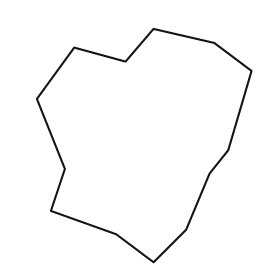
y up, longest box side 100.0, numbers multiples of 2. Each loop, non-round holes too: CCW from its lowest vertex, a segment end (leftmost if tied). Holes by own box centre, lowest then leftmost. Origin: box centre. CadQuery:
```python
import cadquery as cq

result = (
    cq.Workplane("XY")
    .moveTo(4.0, -50.0)
    .lineTo(18.0, -36.0)
    .lineTo(28.0, -12.0)
    .lineTo(36.0, -2.0)
    .lineTo(46.0, 32.0)
    .lineTo(30.0, 44.0)
    .lineTo(4.0, 50.0)
    .lineTo(-8.0, 36.0)
    .lineTo(-30.0, 42.0)
    .lineTo(-46.0, 20.0)
    .lineTo(-34.0, -10.0)
    .lineTo(-40.0, -28.0)
    .lineTo(-12.0, -38.0)
    .close()
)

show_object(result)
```